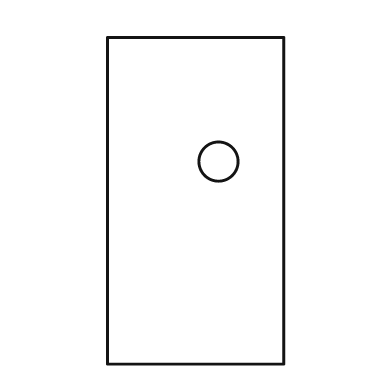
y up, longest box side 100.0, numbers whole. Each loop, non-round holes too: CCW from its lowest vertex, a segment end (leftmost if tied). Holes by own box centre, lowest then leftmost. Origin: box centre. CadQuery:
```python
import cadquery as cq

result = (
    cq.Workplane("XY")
    .moveTo(-27.0, -50.0)
    .lineTo(27.0, -50.0)
    .lineTo(27.0, 50.0)
    .lineTo(-27.0, 50.0)
    .close()
    .moveTo(7.0, 12.0)
    .circle(6.0)
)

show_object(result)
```